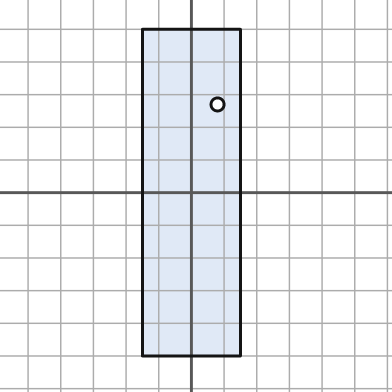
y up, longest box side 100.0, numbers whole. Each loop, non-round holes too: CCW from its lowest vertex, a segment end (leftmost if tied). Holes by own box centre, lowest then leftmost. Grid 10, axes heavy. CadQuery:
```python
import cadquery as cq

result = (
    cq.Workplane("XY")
    .moveTo(-15.0, -50.0)
    .lineTo(15.0, -50.0)
    .lineTo(15.0, 50.0)
    .lineTo(-15.0, 50.0)
    .close()
    .moveTo(8.0, 27.0)
    .circle(2.0)
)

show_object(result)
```